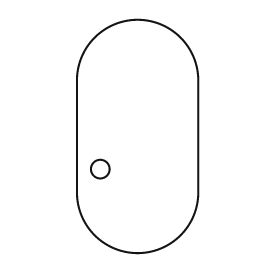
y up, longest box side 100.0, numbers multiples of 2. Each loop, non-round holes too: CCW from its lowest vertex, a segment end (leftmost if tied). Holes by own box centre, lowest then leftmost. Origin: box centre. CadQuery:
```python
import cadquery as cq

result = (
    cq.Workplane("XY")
    .moveTo(-26.0, -24.0)
    .threePointArc((0.0, -50.0), (26.0, -24.0))
    .lineTo(26.0, 24.0)
    .threePointArc((0.0, 50.0), (-26.0, 24.0))
    .close()
    .moveTo(-16.0, -14.0)
    .circle(4.0)
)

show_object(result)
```